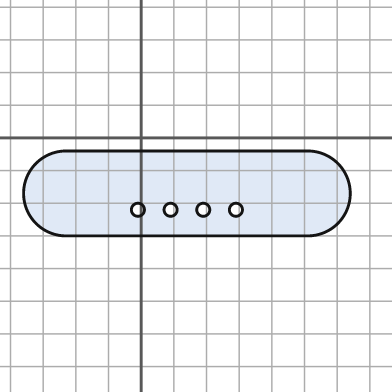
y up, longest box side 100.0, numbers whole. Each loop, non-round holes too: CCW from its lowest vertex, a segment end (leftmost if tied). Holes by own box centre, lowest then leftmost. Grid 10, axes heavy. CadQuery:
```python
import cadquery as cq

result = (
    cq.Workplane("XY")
    .moveTo(-23.0, -30.0)
    .lineTo(51.0, -30.0)
    .threePointArc((64.0, -17.0), (51.0, -4.0))
    .lineTo(-23.0, -4.0)
    .threePointArc((-36.0, -17.0), (-23.0, -30.0))
    .close()
    .moveTo(-1.0, -22.0)
    .circle(2.0)
    .moveTo(9.0, -22.0)
    .circle(2.0)
    .moveTo(19.0, -22.0)
    .circle(2.0)
    .moveTo(29.0, -22.0)
    .circle(2.0)
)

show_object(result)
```